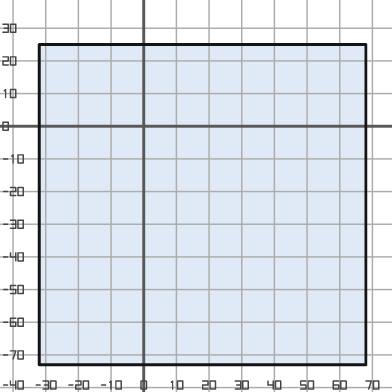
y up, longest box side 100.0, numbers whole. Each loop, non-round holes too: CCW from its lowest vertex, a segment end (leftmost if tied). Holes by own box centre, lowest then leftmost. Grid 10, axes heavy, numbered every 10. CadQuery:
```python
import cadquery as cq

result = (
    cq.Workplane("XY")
    .moveTo(-32.0, -73.0)
    .lineTo(68.0, -73.0)
    .lineTo(68.0, 25.0)
    .lineTo(-32.0, 25.0)
    .close()
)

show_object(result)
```